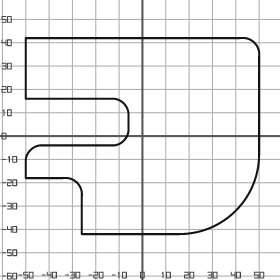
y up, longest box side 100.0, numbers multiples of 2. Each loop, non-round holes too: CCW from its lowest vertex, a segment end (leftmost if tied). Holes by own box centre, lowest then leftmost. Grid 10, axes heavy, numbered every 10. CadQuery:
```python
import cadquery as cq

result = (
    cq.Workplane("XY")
    .moveTo(-26.0, -42.0)
    .lineTo(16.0, -42.0)
    .threePointArc((40.0, -32.0), (50.0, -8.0))
    .lineTo(50.0, 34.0)
    .threePointArc((48.0, 40.0), (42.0, 42.0))
    .lineTo(-50.0, 42.0)
    .lineTo(-50.0, 16.0)
    .lineTo(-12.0, 16.0)
    .threePointArc((-8.0, 14.0), (-6.0, 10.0))
    .lineTo(-6.0, 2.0)
    .threePointArc((-8.0, -2.0), (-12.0, -4.0))
    .lineTo(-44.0, -4.0)
    .threePointArc((-48.0, -6.0), (-50.0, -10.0))
    .lineTo(-50.0, -18.0)
    .lineTo(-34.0, -18.0)
    .threePointArc((-28.0, -20.0), (-26.0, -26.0))
    .close()
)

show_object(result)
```